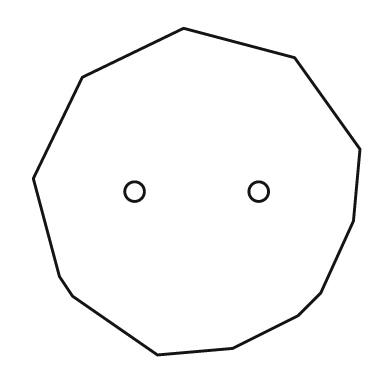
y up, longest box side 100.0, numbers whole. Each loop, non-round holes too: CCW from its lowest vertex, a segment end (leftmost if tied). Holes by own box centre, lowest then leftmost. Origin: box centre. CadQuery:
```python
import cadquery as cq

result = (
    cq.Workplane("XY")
    .moveTo(-12.0, -50.0)
    .lineTo(11.0, -48.0)
    .lineTo(31.0, -38.0)
    .lineTo(38.0, -31.0)
    .lineTo(48.0, -9.0)
    .lineTo(50.0, 13.0)
    .lineTo(30.0, 41.0)
    .lineTo(-4.0, 50.0)
    .lineTo(-35.0, 35.0)
    .lineTo(-50.0, 4.0)
    .lineTo(-42.0, -26.0)
    .lineTo(-38.0, -32.0)
    .close()
    .moveTo(-19.0, 0.0)
    .circle(3.0)
    .moveTo(19.0, 0.0)
    .circle(3.0)
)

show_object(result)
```